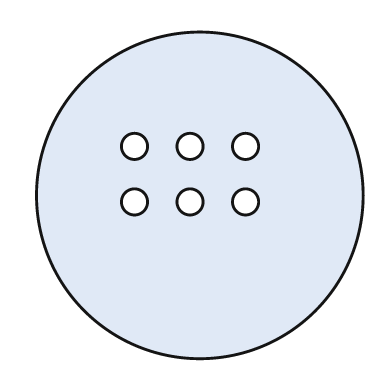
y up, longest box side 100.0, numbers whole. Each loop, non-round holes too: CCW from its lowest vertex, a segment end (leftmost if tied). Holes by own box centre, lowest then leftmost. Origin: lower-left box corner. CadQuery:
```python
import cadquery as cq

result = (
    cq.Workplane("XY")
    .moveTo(50.0, 50.0)
    .circle(50.0)
    .moveTo(30.0, 48.0)
    .circle(4.0)
    .moveTo(47.0, 48.0)
    .circle(4.0)
    .moveTo(64.0, 48.0)
    .circle(4.0)
    .moveTo(30.0, 65.0)
    .circle(4.0)
    .moveTo(47.0, 65.0)
    .circle(4.0)
    .moveTo(64.0, 65.0)
    .circle(4.0)
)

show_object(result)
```